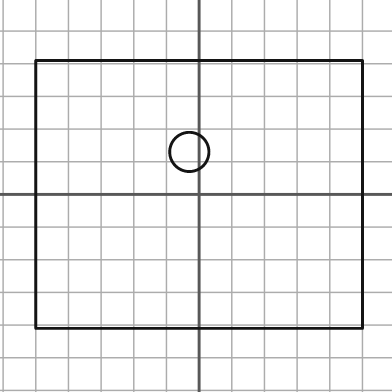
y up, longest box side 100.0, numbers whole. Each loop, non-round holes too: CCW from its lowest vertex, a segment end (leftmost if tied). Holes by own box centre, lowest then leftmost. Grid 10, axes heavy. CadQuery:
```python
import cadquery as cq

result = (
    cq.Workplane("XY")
    .moveTo(-50.0, -41.0)
    .lineTo(50.0, -41.0)
    .lineTo(50.0, 41.0)
    .lineTo(-50.0, 41.0)
    .close()
    .moveTo(-3.0, 13.0)
    .circle(6.0)
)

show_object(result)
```